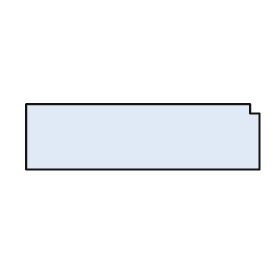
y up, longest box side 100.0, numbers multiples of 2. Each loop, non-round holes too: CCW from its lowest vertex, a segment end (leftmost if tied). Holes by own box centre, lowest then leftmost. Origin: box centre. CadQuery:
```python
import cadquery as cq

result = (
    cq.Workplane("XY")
    .moveTo(-50.0, -14.0)
    .lineTo(50.0, -14.0)
    .lineTo(50.0, 10.0)
    .lineTo(46.0, 10.0)
    .lineTo(46.0, 14.0)
    .lineTo(-50.0, 14.0)
    .close()
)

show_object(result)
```